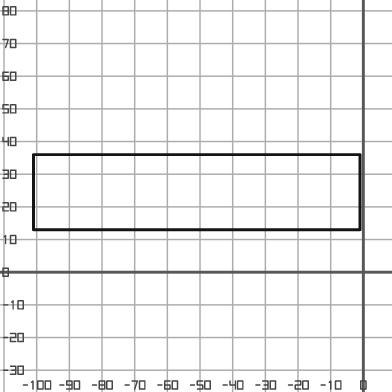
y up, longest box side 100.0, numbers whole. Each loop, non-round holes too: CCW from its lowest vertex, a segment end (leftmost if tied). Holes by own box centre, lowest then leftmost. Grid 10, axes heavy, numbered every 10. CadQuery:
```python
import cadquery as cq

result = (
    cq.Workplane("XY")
    .moveTo(-101.0, 13.0)
    .lineTo(-1.0, 13.0)
    .lineTo(-1.0, 36.0)
    .lineTo(-101.0, 36.0)
    .close()
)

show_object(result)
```